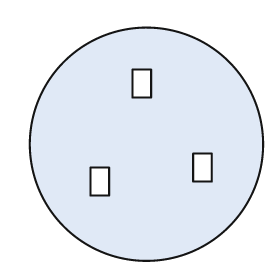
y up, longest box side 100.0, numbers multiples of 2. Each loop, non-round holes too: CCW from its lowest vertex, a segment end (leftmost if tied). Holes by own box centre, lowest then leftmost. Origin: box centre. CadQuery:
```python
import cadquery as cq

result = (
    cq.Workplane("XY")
    .moveTo(0.0, 0.0)
    .circle(50.0)
    .moveTo(-24.0, -22.0)
    .lineTo(-16.0, -22.0)
    .lineTo(-16.0, -10.0)
    .lineTo(-24.0, -10.0)
    .close()
    .moveTo(20.0, -16.0)
    .lineTo(28.0, -16.0)
    .lineTo(28.0, -4.0)
    .lineTo(20.0, -4.0)
    .close()
    .moveTo(-6.0, 20.0)
    .lineTo(2.0, 20.0)
    .lineTo(2.0, 32.0)
    .lineTo(-6.0, 32.0)
    .close()
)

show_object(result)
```